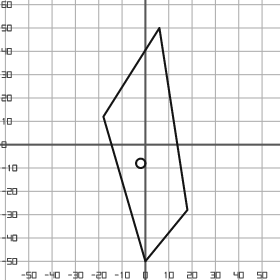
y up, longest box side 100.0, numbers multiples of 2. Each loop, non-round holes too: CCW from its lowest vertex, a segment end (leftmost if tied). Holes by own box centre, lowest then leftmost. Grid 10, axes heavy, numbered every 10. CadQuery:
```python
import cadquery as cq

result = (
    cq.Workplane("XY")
    .moveTo(0.0, -50.0)
    .lineTo(18.0, -28.0)
    .lineTo(6.0, 50.0)
    .lineTo(-18.0, 12.0)
    .close()
    .moveTo(-2.0, -8.0)
    .circle(2.0)
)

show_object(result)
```